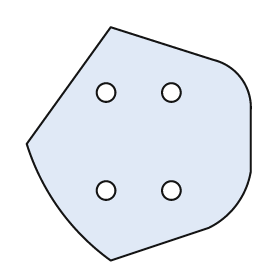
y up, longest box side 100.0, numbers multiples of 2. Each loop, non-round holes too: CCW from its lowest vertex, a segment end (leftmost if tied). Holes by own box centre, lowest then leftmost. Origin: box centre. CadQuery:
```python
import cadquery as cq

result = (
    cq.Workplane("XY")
    .moveTo(-12.0, -50.0)
    .lineTo(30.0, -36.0)
    .threePointArc((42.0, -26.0), (48.0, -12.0))
    .lineTo(48.0, 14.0)
    .threePointArc((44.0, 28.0), (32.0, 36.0))
    .lineTo(-12.0, 50.0)
    .lineTo(-48.0, 0.0)
    .threePointArc((-34.0, -28.0), (-12.0, -50.0))
    .close()
    .moveTo(-14.0, -20.0)
    .circle(4.0)
    .moveTo(14.0, -20.0)
    .circle(4.0)
    .moveTo(-14.0, 22.0)
    .circle(4.0)
    .moveTo(14.0, 22.0)
    .circle(4.0)
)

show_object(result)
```